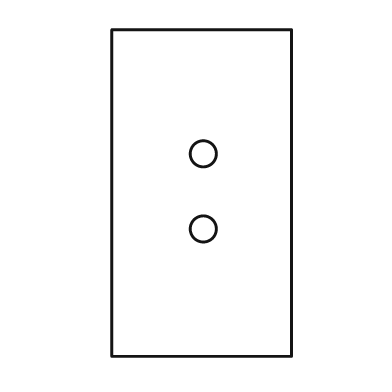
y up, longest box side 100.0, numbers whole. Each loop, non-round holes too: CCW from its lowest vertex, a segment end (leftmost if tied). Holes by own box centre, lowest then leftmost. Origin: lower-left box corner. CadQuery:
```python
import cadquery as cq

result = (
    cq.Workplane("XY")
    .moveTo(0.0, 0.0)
    .lineTo(55.0, 0.0)
    .lineTo(55.0, 100.0)
    .lineTo(0.0, 100.0)
    .close()
    .moveTo(28.0, 39.0)
    .circle(4.0)
    .moveTo(28.0, 62.0)
    .circle(4.0)
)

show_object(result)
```